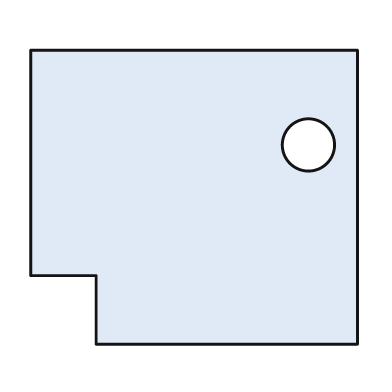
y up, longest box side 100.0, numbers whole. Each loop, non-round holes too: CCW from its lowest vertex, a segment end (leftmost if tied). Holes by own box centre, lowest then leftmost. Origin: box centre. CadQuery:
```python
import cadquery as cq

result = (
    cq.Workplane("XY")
    .moveTo(-30.0, -45.0)
    .lineTo(50.0, -45.0)
    .lineTo(50.0, 45.0)
    .lineTo(-50.0, 45.0)
    .lineTo(-50.0, -24.0)
    .lineTo(-30.0, -24.0)
    .close()
    .moveTo(35.0, 16.0)
    .circle(8.0)
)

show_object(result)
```